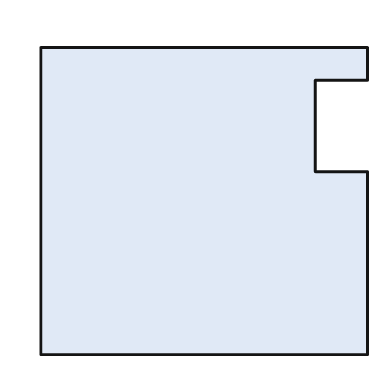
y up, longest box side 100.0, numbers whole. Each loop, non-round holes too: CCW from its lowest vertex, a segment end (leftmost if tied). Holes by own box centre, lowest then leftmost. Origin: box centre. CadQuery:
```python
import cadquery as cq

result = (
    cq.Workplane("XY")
    .moveTo(-50.0, -47.0)
    .lineTo(50.0, -47.0)
    .lineTo(50.0, 9.0)
    .lineTo(34.0, 9.0)
    .lineTo(34.0, 37.0)
    .lineTo(50.0, 37.0)
    .lineTo(50.0, 47.0)
    .lineTo(-50.0, 47.0)
    .close()
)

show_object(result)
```